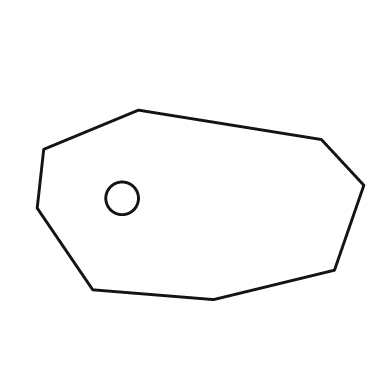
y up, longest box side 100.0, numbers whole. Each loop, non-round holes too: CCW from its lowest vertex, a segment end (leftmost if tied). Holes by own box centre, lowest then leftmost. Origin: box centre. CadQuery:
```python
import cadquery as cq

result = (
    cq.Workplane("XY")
    .moveTo(4.0, -29.0)
    .lineTo(41.0, -20.0)
    .lineTo(50.0, 6.0)
    .lineTo(37.0, 20.0)
    .lineTo(-19.0, 29.0)
    .lineTo(-48.0, 17.0)
    .lineTo(-50.0, -1.0)
    .lineTo(-33.0, -26.0)
    .close()
    .moveTo(-24.0, 2.0)
    .circle(5.0)
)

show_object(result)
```